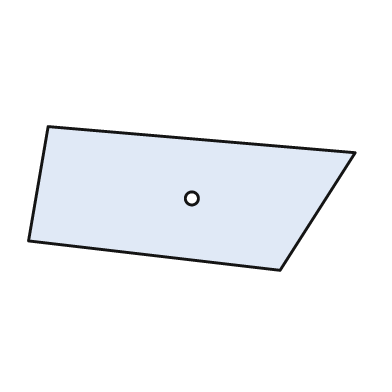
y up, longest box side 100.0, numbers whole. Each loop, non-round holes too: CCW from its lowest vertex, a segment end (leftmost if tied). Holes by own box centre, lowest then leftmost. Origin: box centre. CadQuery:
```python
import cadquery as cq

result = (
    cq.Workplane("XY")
    .moveTo(27.0, -22.0)
    .lineTo(50.0, 14.0)
    .lineTo(-44.0, 22.0)
    .lineTo(-50.0, -13.0)
    .close()
    .moveTo(0.0, 0.0)
    .circle(2.0)
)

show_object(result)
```